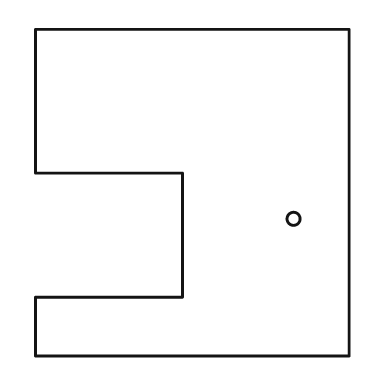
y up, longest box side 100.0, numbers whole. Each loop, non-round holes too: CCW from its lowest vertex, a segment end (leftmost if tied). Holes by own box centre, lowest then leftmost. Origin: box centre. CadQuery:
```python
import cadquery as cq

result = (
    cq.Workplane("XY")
    .moveTo(-48.0, -50.0)
    .lineTo(48.0, -50.0)
    .lineTo(48.0, 50.0)
    .lineTo(-48.0, 50.0)
    .lineTo(-48.0, 6.0)
    .lineTo(-3.0, 6.0)
    .lineTo(-3.0, -32.0)
    .lineTo(-48.0, -32.0)
    .close()
    .moveTo(31.0, -8.0)
    .circle(2.0)
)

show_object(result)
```